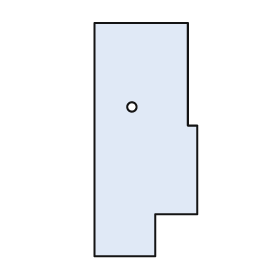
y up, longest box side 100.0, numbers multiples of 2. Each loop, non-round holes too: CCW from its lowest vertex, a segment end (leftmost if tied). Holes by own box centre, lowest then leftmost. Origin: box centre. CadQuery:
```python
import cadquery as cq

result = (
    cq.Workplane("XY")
    .moveTo(-22.0, -50.0)
    .lineTo(4.0, -50.0)
    .lineTo(4.0, -32.0)
    .lineTo(22.0, -32.0)
    .lineTo(22.0, 6.0)
    .lineTo(18.0, 6.0)
    .lineTo(18.0, 50.0)
    .lineTo(-22.0, 50.0)
    .close()
    .moveTo(-6.0, 14.0)
    .circle(2.0)
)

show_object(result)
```